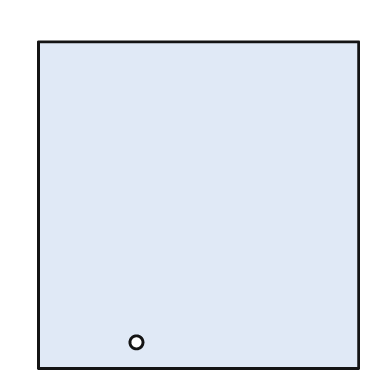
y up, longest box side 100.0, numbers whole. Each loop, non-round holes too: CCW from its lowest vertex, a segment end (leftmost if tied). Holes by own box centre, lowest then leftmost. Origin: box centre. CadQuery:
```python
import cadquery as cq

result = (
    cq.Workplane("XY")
    .moveTo(-49.0, -50.0)
    .lineTo(49.0, -50.0)
    .lineTo(49.0, 50.0)
    .lineTo(-49.0, 50.0)
    .close()
    .moveTo(-19.0, -42.0)
    .circle(2.0)
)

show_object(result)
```